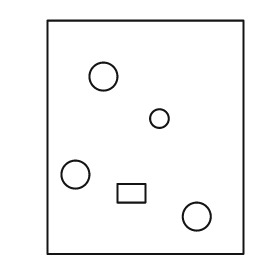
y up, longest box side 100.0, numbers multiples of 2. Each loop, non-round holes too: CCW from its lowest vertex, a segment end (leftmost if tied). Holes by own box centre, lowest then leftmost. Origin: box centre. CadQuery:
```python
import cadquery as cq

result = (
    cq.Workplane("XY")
    .moveTo(-42.0, -50.0)
    .lineTo(42.0, -50.0)
    .lineTo(42.0, 50.0)
    .lineTo(-42.0, 50.0)
    .close()
    .moveTo(22.0, -34.0)
    .circle(6.0)
    .moveTo(-12.0, -28.0)
    .lineTo(0.0, -28.0)
    .lineTo(0.0, -20.0)
    .lineTo(-12.0, -20.0)
    .close()
    .moveTo(-30.0, -16.0)
    .circle(6.0)
    .moveTo(6.0, 8.0)
    .circle(4.0)
    .moveTo(-18.0, 26.0)
    .circle(6.0)
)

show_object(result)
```